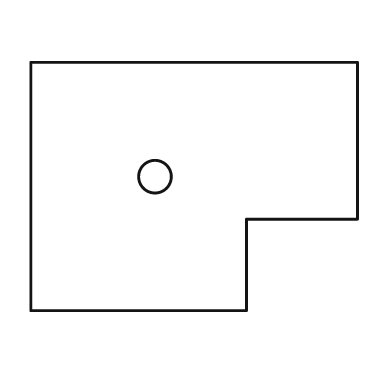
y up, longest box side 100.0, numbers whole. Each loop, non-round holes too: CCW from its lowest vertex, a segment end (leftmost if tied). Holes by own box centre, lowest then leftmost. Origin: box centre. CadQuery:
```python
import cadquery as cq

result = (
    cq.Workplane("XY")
    .moveTo(-50.0, -38.0)
    .lineTo(16.0, -38.0)
    .lineTo(16.0, -10.0)
    .lineTo(50.0, -10.0)
    .lineTo(50.0, 38.0)
    .lineTo(-50.0, 38.0)
    .close()
    .moveTo(-12.0, 3.0)
    .circle(5.0)
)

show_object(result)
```